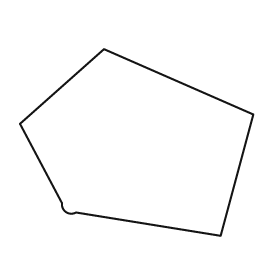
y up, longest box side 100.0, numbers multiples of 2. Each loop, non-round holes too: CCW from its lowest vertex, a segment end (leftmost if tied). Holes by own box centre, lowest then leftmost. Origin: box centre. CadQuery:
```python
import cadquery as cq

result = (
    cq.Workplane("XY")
    .moveTo(36.0, -40.0)
    .lineTo(50.0, 12.0)
    .lineTo(-14.0, 40.0)
    .lineTo(-50.0, 8.0)
    .lineTo(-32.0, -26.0)
    .threePointArc((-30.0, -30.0), (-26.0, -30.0))
    .close()
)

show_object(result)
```